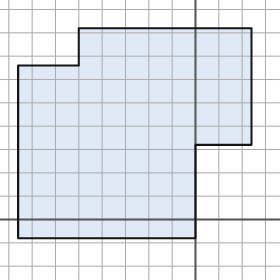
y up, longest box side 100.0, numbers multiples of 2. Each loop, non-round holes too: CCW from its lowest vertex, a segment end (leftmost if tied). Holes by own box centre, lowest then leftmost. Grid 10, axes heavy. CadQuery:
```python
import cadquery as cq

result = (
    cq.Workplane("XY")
    .moveTo(-76.0, -8.0)
    .lineTo(0.0, -8.0)
    .lineTo(0.0, 32.0)
    .lineTo(24.0, 32.0)
    .lineTo(24.0, 82.0)
    .lineTo(-50.0, 82.0)
    .lineTo(-50.0, 66.0)
    .lineTo(-76.0, 66.0)
    .close()
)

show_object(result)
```